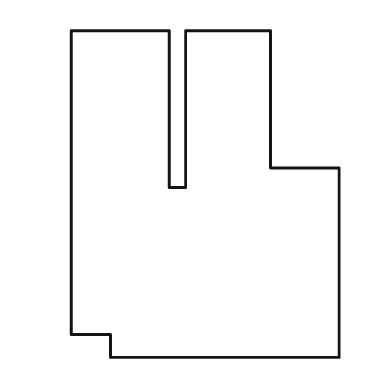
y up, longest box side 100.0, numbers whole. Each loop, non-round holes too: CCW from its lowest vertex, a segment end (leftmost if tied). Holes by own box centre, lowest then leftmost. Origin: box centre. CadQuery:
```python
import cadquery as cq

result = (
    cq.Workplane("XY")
    .moveTo(-29.0, -50.0)
    .lineTo(41.0, -50.0)
    .lineTo(41.0, 8.0)
    .lineTo(20.0, 8.0)
    .lineTo(20.0, 50.0)
    .lineTo(-6.0, 50.0)
    .lineTo(-6.0, 2.0)
    .lineTo(-11.0, 2.0)
    .lineTo(-11.0, 50.0)
    .lineTo(-41.0, 50.0)
    .lineTo(-41.0, -43.0)
    .lineTo(-29.0, -43.0)
    .close()
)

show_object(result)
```